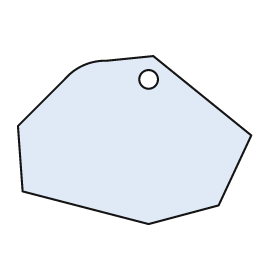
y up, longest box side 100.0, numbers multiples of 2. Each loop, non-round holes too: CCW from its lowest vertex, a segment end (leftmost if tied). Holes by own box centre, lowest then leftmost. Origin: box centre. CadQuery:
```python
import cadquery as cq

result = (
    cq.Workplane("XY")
    .moveTo(6.0, -36.0)
    .lineTo(36.0, -28.0)
    .lineTo(50.0, 2.0)
    .lineTo(8.0, 36.0)
    .lineTo(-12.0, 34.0)
    .threePointArc((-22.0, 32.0), (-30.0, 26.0))
    .lineTo(-50.0, 6.0)
    .lineTo(-48.0, -22.0)
    .close()
    .moveTo(6.0, 26.0)
    .circle(4.0)
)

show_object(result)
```